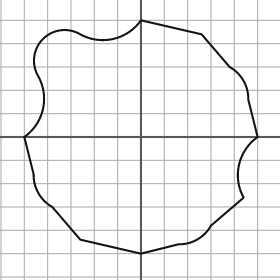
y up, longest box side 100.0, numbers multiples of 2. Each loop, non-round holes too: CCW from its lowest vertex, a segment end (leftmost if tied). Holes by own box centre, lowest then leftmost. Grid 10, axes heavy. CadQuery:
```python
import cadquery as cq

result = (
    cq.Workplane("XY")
    .moveTo(0.0, -50.0)
    .lineTo(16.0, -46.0)
    .threePointArc((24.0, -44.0), (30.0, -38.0))
    .lineTo(44.0, -26.0)
    .threePointArc((42.0, -12.0), (50.0, 0.0))
    .lineTo(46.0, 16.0)
    .threePointArc((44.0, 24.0), (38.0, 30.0))
    .lineTo(26.0, 44.0)
    .lineTo(0.0, 50.0)
    .threePointArc((-12.0, 42.0), (-26.0, 44.0))
    .threePointArc((-42.0, 42.0), (-44.0, 26.0))
    .threePointArc((-42.0, 12.0), (-50.0, 0.0))
    .lineTo(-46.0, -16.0)
    .threePointArc((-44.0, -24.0), (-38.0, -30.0))
    .lineTo(-26.0, -44.0)
    .close()
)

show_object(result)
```